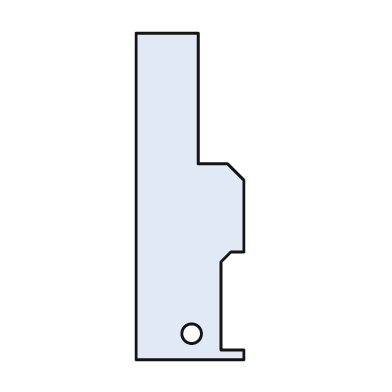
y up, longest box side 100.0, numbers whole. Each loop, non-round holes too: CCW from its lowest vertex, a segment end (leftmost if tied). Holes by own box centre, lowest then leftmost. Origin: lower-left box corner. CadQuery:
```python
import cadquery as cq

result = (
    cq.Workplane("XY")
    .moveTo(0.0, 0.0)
    .lineTo(33.0, 0.0)
    .lineTo(33.0, 3.0)
    .lineTo(26.0, 3.0)
    .lineTo(26.0, 30.0)
    .lineTo(29.0, 33.0)
    .lineTo(33.0, 33.0)
    .lineTo(33.0, 55.0)
    .lineTo(28.0, 60.0)
    .lineTo(19.0, 60.0)
    .lineTo(19.0, 100.0)
    .lineTo(0.0, 100.0)
    .close()
    .moveTo(17.0, 8.0)
    .circle(3.0)
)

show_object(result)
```